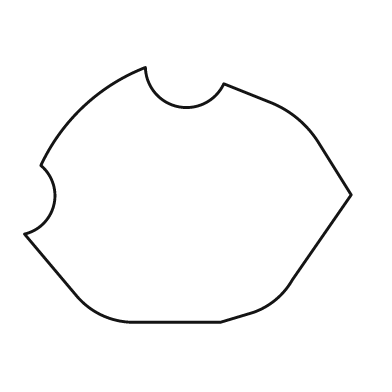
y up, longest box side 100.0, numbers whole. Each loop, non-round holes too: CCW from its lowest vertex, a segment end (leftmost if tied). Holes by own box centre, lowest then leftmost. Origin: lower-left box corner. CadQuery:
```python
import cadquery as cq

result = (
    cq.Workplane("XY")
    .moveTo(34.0, 0.0)
    .lineTo(60.0, 0.0)
    .lineTo(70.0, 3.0)
    .threePointArc((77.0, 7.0), (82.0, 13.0))
    .lineTo(100.0, 39.0)
    .lineTo(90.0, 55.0)
    .threePointArc((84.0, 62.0), (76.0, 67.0))
    .lineTo(61.0, 73.0)
    .threePointArc((47.0, 66.0), (37.0, 78.0))
    .threePointArc((18.0, 66.0), (5.0, 48.0))
    .threePointArc((9.0, 36.0), (0.0, 27.0))
    .lineTo(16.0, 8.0)
    .threePointArc((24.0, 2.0), (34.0, 0.0))
    .close()
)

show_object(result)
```